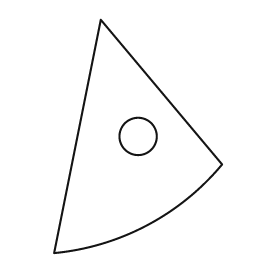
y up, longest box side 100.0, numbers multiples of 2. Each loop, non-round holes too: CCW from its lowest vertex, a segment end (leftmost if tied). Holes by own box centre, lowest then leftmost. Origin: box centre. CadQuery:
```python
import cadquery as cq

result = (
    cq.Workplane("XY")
    .moveTo(-36.0, -50.0)
    .threePointArc((4.0, -38.0), (36.0, -12.0))
    .lineTo(-16.0, 50.0)
    .close()
    .moveTo(0.0, 0.0)
    .circle(8.0)
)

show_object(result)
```